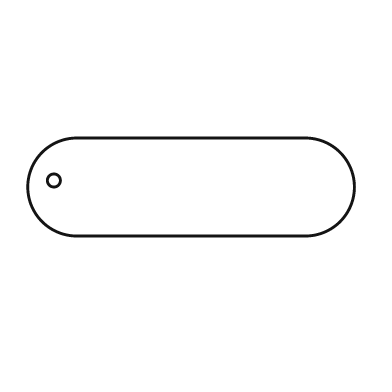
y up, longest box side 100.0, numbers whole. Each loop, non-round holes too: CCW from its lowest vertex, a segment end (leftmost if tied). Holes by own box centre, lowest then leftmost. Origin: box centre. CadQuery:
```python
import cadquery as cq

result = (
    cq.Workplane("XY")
    .moveTo(-35.0, -15.0)
    .lineTo(35.0, -15.0)
    .threePointArc((50.0, 0.0), (35.0, 15.0))
    .lineTo(-35.0, 15.0)
    .threePointArc((-50.0, 0.0), (-35.0, -15.0))
    .close()
    .moveTo(-42.0, 2.0)
    .circle(2.0)
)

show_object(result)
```